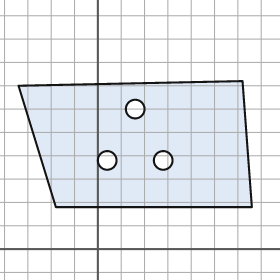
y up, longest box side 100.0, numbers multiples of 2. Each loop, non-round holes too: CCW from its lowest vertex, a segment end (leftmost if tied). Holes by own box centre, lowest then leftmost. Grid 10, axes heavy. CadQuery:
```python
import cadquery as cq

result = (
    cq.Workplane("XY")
    .moveTo(-18.0, 18.0)
    .lineTo(66.0, 18.0)
    .lineTo(62.0, 72.0)
    .lineTo(-34.0, 70.0)
    .close()
    .moveTo(4.0, 38.0)
    .circle(4.0)
    .moveTo(28.0, 38.0)
    .circle(4.0)
    .moveTo(16.0, 60.0)
    .circle(4.0)
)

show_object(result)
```